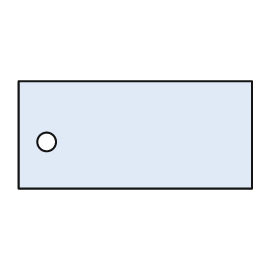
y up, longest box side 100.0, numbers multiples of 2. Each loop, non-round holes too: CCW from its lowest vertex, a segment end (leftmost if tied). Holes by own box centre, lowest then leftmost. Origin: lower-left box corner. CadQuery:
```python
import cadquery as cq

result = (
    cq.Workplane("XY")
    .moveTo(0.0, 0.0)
    .lineTo(100.0, 0.0)
    .lineTo(100.0, 46.0)
    .lineTo(0.0, 46.0)
    .close()
    .moveTo(12.0, 20.0)
    .circle(4.0)
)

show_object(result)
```